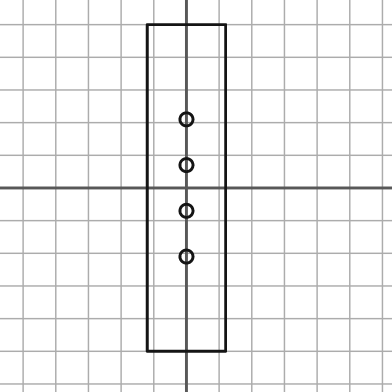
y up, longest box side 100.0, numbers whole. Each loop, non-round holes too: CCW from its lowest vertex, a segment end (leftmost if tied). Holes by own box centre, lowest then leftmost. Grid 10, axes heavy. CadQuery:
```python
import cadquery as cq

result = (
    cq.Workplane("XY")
    .moveTo(-12.0, -50.0)
    .lineTo(12.0, -50.0)
    .lineTo(12.0, 50.0)
    .lineTo(-12.0, 50.0)
    .close()
    .moveTo(0.0, -21.0)
    .circle(2.0)
    .moveTo(0.0, -7.0)
    .circle(2.0)
    .moveTo(0.0, 7.0)
    .circle(2.0)
    .moveTo(0.0, 21.0)
    .circle(2.0)
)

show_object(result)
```